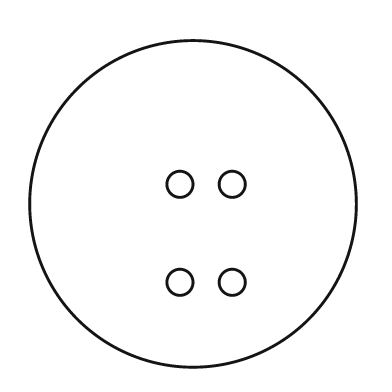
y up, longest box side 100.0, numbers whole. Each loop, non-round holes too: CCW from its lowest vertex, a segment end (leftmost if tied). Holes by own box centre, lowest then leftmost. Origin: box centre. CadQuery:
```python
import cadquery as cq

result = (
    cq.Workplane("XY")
    .moveTo(0.0, 0.0)
    .circle(50.0)
    .moveTo(-4.0, -24.0)
    .circle(4.0)
    .moveTo(12.0, -24.0)
    .circle(4.0)
    .moveTo(-4.0, 6.0)
    .circle(4.0)
    .moveTo(12.0, 6.0)
    .circle(4.0)
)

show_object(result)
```